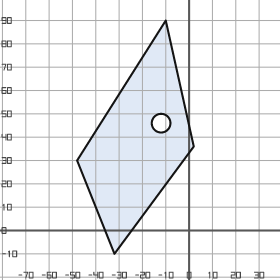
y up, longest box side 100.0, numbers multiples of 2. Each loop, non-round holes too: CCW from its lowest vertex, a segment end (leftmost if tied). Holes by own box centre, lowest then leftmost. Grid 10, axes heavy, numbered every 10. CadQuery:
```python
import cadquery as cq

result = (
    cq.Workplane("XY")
    .moveTo(-32.0, -10.0)
    .lineTo(2.0, 36.0)
    .lineTo(-10.0, 90.0)
    .lineTo(-48.0, 30.0)
    .close()
    .moveTo(-12.0, 46.0)
    .circle(4.0)
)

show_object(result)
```